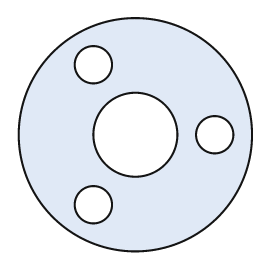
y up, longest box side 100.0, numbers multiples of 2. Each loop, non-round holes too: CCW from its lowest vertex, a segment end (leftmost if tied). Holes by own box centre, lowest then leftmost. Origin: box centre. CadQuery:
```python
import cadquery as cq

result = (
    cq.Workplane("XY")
    .moveTo(0.0, 0.0)
    .circle(50.0)
    .moveTo(-18.0, -30.0)
    .circle(8.0)
    .moveTo(0.0, 0.0)
    .circle(18.0)
    .moveTo(34.0, 0.0)
    .circle(8.0)
    .moveTo(-18.0, 30.0)
    .circle(8.0)
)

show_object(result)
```